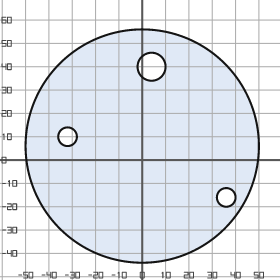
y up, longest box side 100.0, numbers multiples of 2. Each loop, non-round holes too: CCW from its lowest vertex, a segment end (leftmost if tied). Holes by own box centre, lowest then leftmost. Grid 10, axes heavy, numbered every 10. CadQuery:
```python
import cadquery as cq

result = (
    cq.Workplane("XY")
    .moveTo(0.0, 6.0)
    .circle(50.0)
    .moveTo(36.0, -16.0)
    .circle(4.0)
    .moveTo(-32.0, 10.0)
    .circle(4.0)
    .moveTo(4.0, 40.0)
    .circle(6.0)
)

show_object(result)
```